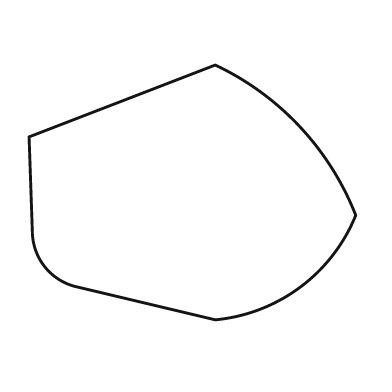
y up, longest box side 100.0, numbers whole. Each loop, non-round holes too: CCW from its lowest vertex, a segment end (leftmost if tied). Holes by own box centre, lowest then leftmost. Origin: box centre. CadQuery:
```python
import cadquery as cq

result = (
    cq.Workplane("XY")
    .moveTo(7.0, -39.0)
    .threePointArc((33.0, -29.0), (50.0, -7.0))
    .threePointArc((33.0, 20.0), (7.0, 39.0))
    .lineTo(-50.0, 17.0)
    .lineTo(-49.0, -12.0)
    .threePointArc((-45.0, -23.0), (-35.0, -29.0))
    .close()
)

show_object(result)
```